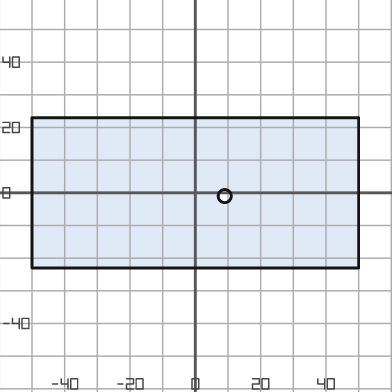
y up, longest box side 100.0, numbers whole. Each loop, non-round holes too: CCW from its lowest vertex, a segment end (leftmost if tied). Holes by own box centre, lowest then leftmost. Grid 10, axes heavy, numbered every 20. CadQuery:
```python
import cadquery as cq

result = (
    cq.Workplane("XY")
    .moveTo(-50.0, -23.0)
    .lineTo(50.0, -23.0)
    .lineTo(50.0, 23.0)
    .lineTo(-50.0, 23.0)
    .close()
    .moveTo(9.0, -1.0)
    .circle(2.0)
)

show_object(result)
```